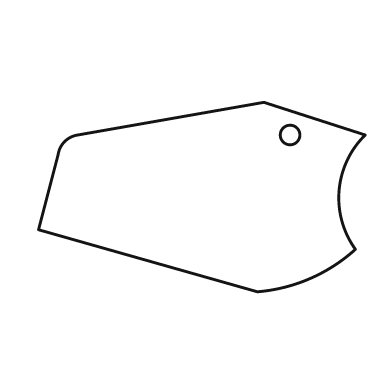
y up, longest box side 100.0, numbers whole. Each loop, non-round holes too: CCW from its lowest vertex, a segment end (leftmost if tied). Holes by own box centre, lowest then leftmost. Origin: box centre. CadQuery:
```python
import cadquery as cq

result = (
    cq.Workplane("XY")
    .moveTo(17.0, -29.0)
    .threePointArc((33.0, -25.0), (47.0, -16.0))
    .threePointArc((42.0, 2.0), (50.0, 19.0))
    .lineTo(19.0, 29.0)
    .lineTo(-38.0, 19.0)
    .threePointArc((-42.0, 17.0), (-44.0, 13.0))
    .lineTo(-50.0, -10.0)
    .close()
    .moveTo(27.0, 19.0)
    .circle(3.0)
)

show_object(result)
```